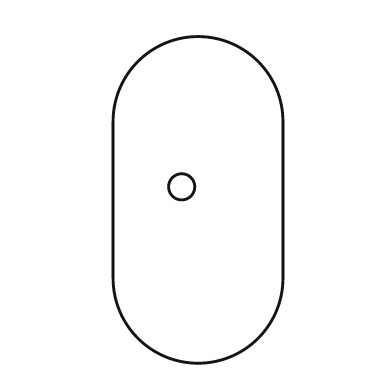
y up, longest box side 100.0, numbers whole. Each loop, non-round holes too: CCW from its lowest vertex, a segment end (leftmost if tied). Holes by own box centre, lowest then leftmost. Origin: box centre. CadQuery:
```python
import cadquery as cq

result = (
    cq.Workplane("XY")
    .moveTo(-26.0, -24.0)
    .threePointArc((0.0, -50.0), (26.0, -24.0))
    .lineTo(26.0, 24.0)
    .threePointArc((0.0, 50.0), (-26.0, 24.0))
    .close()
    .moveTo(-5.0, 4.0)
    .circle(4.0)
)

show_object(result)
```